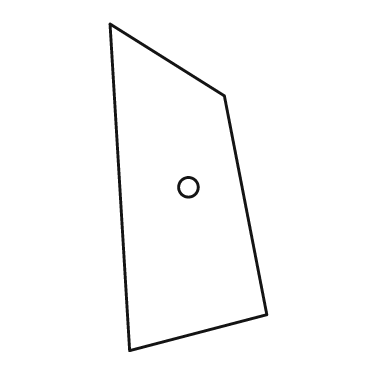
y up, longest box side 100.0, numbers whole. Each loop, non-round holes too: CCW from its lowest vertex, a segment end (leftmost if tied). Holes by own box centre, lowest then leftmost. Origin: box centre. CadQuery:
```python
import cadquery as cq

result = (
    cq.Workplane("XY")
    .moveTo(-18.0, -50.0)
    .lineTo(24.0, -39.0)
    .lineTo(11.0, 28.0)
    .lineTo(-24.0, 50.0)
    .close()
    .moveTo(0.0, 0.0)
    .circle(3.0)
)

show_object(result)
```